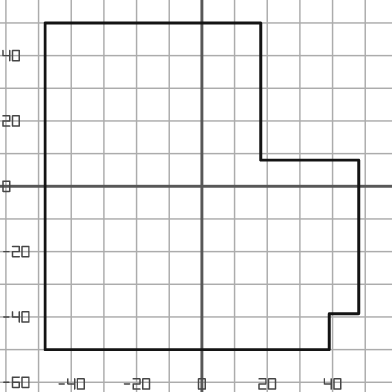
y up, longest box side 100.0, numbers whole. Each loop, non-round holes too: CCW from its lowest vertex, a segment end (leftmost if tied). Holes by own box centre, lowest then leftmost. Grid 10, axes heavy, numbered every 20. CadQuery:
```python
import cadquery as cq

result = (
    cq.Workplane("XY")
    .moveTo(-48.0, -50.0)
    .lineTo(39.0, -50.0)
    .lineTo(39.0, -39.0)
    .lineTo(48.0, -39.0)
    .lineTo(48.0, 8.0)
    .lineTo(18.0, 8.0)
    .lineTo(18.0, 50.0)
    .lineTo(-48.0, 50.0)
    .close()
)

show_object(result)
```